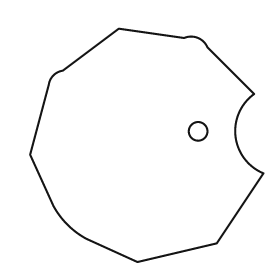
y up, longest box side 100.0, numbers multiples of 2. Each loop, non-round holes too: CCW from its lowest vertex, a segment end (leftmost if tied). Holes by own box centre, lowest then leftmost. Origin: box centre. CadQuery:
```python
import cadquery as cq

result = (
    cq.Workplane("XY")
    .moveTo(-4.0, -50.0)
    .lineTo(30.0, -42.0)
    .lineTo(50.0, -12.0)
    .threePointArc((38.0, 4.0), (46.0, 22.0))
    .lineTo(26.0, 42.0)
    .threePointArc((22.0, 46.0), (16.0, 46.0))
    .lineTo(-12.0, 50.0)
    .lineTo(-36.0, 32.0)
    .threePointArc((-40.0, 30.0), (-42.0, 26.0))
    .lineTo(-50.0, -4.0)
    .lineTo(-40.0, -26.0)
    .threePointArc((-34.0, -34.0), (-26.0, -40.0))
    .close()
    .moveTo(22.0, 6.0)
    .circle(4.0)
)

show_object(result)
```